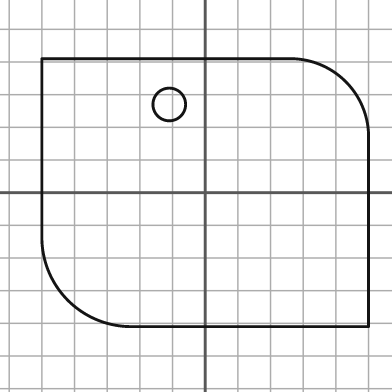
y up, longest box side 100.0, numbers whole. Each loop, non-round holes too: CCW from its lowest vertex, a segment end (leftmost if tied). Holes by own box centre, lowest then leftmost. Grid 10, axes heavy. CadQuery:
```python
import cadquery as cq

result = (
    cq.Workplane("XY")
    .moveTo(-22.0, -41.0)
    .lineTo(50.0, -41.0)
    .lineTo(50.0, 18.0)
    .threePointArc((43.0, 34.0), (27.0, 41.0))
    .lineTo(-50.0, 41.0)
    .lineTo(-50.0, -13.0)
    .threePointArc((-42.0, -33.0), (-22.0, -41.0))
    .close()
    .moveTo(-11.0, 27.0)
    .circle(5.0)
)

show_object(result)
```